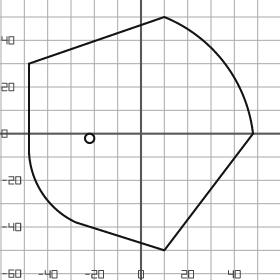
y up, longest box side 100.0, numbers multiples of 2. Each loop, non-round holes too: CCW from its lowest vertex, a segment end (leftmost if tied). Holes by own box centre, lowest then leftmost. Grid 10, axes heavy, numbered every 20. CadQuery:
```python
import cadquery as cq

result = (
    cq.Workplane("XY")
    .moveTo(10.0, -50.0)
    .lineTo(48.0, 0.0)
    .threePointArc((36.0, 30.0), (10.0, 50.0))
    .lineTo(-48.0, 30.0)
    .lineTo(-48.0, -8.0)
    .threePointArc((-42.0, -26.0), (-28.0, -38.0))
    .close()
    .moveTo(-22.0, -2.0)
    .circle(2.0)
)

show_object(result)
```